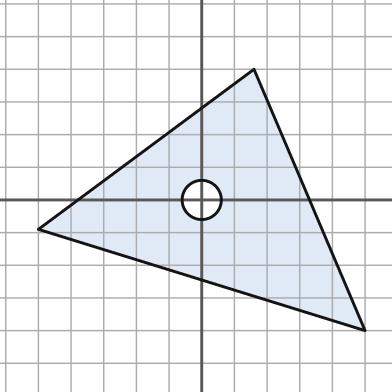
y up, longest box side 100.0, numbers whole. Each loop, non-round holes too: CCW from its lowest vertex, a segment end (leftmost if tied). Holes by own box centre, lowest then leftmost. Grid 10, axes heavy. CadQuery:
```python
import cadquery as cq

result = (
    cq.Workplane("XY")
    .moveTo(50.0, -40.0)
    .lineTo(16.0, 40.0)
    .lineTo(-50.0, -9.0)
    .close()
    .moveTo(0.0, 0.0)
    .circle(6.0)
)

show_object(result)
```